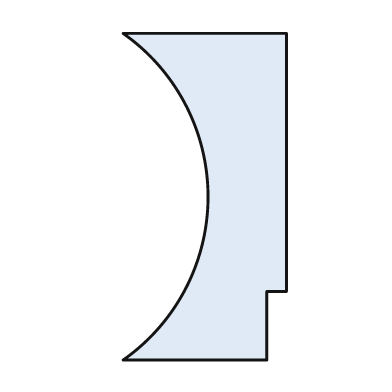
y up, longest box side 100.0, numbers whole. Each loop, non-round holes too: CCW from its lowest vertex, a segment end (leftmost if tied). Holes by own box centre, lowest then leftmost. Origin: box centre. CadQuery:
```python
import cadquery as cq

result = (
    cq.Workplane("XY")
    .moveTo(-25.0, -50.0)
    .lineTo(19.0, -50.0)
    .lineTo(19.0, -29.0)
    .lineTo(25.0, -29.0)
    .lineTo(25.0, 50.0)
    .lineTo(-25.0, 50.0)
    .threePointArc((1.0, 0.0), (-25.0, -50.0))
    .close()
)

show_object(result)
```